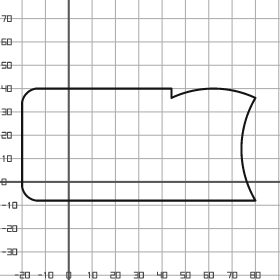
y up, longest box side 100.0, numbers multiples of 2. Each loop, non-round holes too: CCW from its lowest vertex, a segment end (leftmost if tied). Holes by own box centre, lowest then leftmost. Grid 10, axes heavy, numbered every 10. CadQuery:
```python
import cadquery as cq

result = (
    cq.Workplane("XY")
    .moveTo(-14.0, -8.0)
    .lineTo(80.0, -8.0)
    .threePointArc((74.0, 14.0), (80.0, 36.0))
    .threePointArc((62.0, 40.0), (44.0, 36.0))
    .lineTo(44.0, 40.0)
    .lineTo(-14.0, 40.0)
    .threePointArc((-18.0, 38.0), (-20.0, 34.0))
    .lineTo(-20.0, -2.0)
    .threePointArc((-18.0, -6.0), (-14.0, -8.0))
    .close()
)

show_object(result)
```